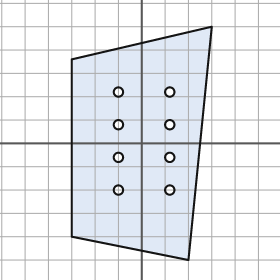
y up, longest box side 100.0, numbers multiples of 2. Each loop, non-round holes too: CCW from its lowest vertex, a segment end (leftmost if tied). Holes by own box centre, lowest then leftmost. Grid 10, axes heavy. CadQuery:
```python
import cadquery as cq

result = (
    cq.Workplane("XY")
    .moveTo(20.0, -50.0)
    .lineTo(30.0, 50.0)
    .lineTo(-30.0, 36.0)
    .lineTo(-30.0, -40.0)
    .close()
    .moveTo(-10.0, -20.0)
    .circle(2.0)
    .moveTo(12.0, -20.0)
    .circle(2.0)
    .moveTo(-10.0, -6.0)
    .circle(2.0)
    .moveTo(12.0, -6.0)
    .circle(2.0)
    .moveTo(-10.0, 8.0)
    .circle(2.0)
    .moveTo(12.0, 8.0)
    .circle(2.0)
    .moveTo(-10.0, 22.0)
    .circle(2.0)
    .moveTo(12.0, 22.0)
    .circle(2.0)
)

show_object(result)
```